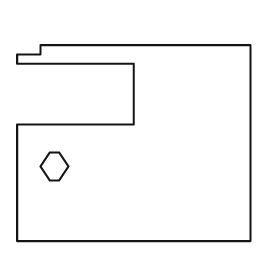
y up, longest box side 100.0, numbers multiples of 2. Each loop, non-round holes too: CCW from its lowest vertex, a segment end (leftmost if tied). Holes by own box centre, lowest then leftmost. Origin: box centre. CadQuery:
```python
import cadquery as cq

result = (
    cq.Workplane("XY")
    .moveTo(-50.0, -42.0)
    .lineTo(50.0, -42.0)
    .lineTo(50.0, 42.0)
    .lineTo(-40.0, 42.0)
    .lineTo(-40.0, 38.0)
    .lineTo(-50.0, 38.0)
    .lineTo(-50.0, 34.0)
    .lineTo(0.0, 34.0)
    .lineTo(0.0, 8.0)
    .lineTo(-50.0, 8.0)
    .close()
    .moveTo(-36.0, -16.0)
    .lineTo(-32.0, -16.0)
    .lineTo(-28.0, -10.0)
    .lineTo(-32.0, -4.0)
    .lineTo(-36.0, -4.0)
    .lineTo(-40.0, -10.0)
    .close()
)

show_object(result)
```